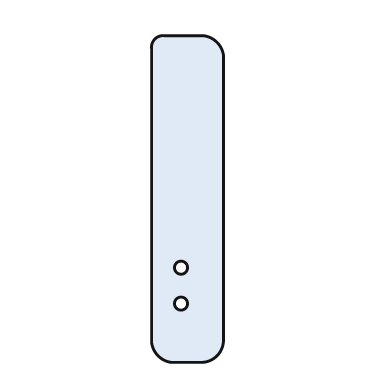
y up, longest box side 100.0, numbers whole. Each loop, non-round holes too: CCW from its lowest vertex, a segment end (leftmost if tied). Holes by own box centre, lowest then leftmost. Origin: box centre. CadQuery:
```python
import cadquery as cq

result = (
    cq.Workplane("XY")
    .moveTo(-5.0, -50.0)
    .lineTo(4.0, -50.0)
    .threePointArc((9.0, -48.0), (11.0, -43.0))
    .lineTo(11.0, 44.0)
    .threePointArc((9.0, 48.0), (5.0, 50.0))
    .lineTo(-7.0, 50.0)
    .threePointArc((-10.0, 49.0), (-11.0, 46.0))
    .lineTo(-11.0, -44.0)
    .threePointArc((-9.0, -48.0), (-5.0, -50.0))
    .close()
    .moveTo(-2.0, -32.0)
    .circle(2.0)
    .moveTo(-2.0, -21.0)
    .circle(2.0)
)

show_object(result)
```